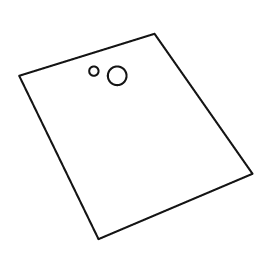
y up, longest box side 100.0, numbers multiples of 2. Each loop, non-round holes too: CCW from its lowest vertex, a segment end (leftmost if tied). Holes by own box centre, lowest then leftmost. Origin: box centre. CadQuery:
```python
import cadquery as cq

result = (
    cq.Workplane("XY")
    .moveTo(-16.0, -44.0)
    .lineTo(50.0, -16.0)
    .lineTo(8.0, 44.0)
    .lineTo(-50.0, 26.0)
    .close()
    .moveTo(-8.0, 26.0)
    .circle(4.0)
    .moveTo(-18.0, 28.0)
    .circle(2.0)
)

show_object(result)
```